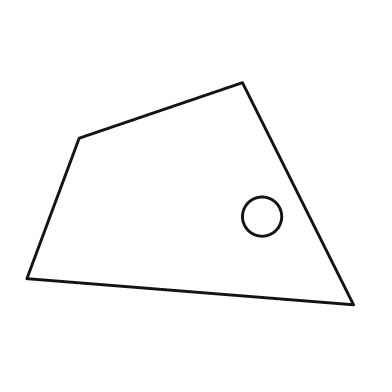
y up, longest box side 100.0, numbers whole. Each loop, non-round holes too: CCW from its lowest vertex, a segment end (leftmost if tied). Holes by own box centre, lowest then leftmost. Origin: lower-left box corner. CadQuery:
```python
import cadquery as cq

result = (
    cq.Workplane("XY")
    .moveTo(100.0, 0.0)
    .lineTo(66.0, 68.0)
    .lineTo(16.0, 51.0)
    .lineTo(0.0, 8.0)
    .close()
    .moveTo(72.0, 27.0)
    .circle(6.0)
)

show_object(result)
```